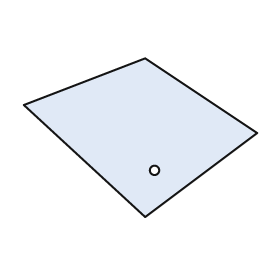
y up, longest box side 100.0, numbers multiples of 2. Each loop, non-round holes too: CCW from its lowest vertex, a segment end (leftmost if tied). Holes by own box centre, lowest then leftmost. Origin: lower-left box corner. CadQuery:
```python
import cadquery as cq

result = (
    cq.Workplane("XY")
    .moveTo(52.0, 0.0)
    .lineTo(100.0, 36.0)
    .lineTo(52.0, 68.0)
    .lineTo(0.0, 48.0)
    .close()
    .moveTo(56.0, 20.0)
    .circle(2.0)
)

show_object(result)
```